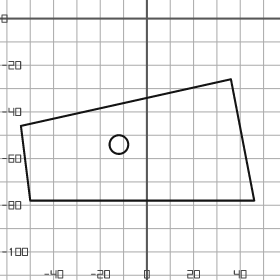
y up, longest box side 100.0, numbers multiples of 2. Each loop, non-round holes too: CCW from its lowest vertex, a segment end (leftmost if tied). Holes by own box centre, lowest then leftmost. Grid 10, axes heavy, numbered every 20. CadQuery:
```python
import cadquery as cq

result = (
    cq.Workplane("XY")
    .moveTo(-50.0, -78.0)
    .lineTo(46.0, -78.0)
    .lineTo(36.0, -26.0)
    .lineTo(-54.0, -46.0)
    .close()
    .moveTo(-12.0, -54.0)
    .circle(4.0)
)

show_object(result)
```